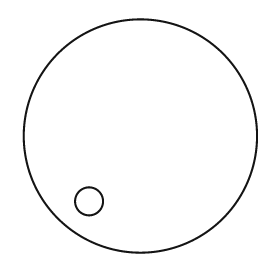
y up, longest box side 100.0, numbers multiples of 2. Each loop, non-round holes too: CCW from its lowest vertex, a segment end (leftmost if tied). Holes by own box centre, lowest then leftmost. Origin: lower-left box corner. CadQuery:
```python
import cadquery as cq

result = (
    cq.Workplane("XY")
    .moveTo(50.0, 50.0)
    .circle(50.0)
    .moveTo(28.0, 22.0)
    .circle(6.0)
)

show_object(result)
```